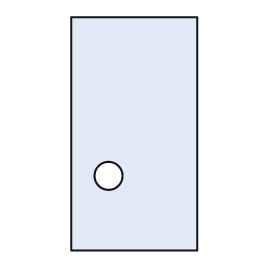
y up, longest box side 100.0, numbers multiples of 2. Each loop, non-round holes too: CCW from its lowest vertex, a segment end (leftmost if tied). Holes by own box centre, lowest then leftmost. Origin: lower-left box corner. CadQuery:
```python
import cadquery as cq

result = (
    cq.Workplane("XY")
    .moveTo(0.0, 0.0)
    .lineTo(54.0, 0.0)
    .lineTo(54.0, 100.0)
    .lineTo(0.0, 100.0)
    .close()
    .moveTo(16.0, 32.0)
    .circle(6.0)
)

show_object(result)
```